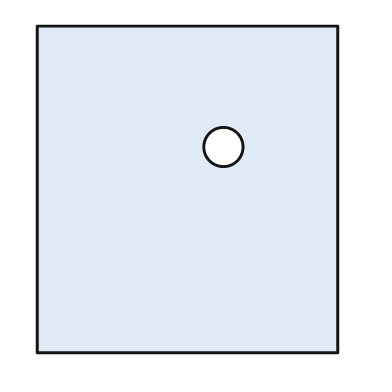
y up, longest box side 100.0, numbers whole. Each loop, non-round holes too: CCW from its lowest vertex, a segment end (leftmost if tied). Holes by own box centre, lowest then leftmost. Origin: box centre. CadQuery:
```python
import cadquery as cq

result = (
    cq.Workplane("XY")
    .moveTo(-46.0, -50.0)
    .lineTo(46.0, -50.0)
    .lineTo(46.0, 50.0)
    .lineTo(-46.0, 50.0)
    .close()
    .moveTo(11.0, 13.0)
    .circle(6.0)
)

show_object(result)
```